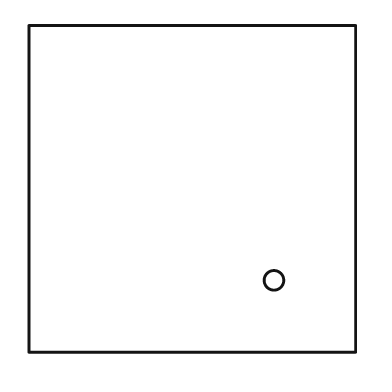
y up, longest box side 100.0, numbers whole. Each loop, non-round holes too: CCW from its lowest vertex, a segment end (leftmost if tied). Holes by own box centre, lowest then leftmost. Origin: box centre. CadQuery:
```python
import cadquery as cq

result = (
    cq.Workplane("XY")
    .moveTo(-50.0, -50.0)
    .lineTo(50.0, -50.0)
    .lineTo(50.0, 50.0)
    .lineTo(-50.0, 50.0)
    .close()
    .moveTo(25.0, -28.0)
    .circle(3.0)
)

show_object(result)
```